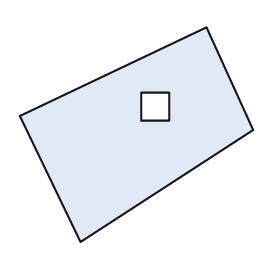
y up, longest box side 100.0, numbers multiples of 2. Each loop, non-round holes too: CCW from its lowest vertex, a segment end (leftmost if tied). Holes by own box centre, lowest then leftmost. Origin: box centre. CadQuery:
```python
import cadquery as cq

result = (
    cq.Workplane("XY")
    .moveTo(-24.0, -46.0)
    .lineTo(50.0, 2.0)
    .lineTo(30.0, 46.0)
    .lineTo(-50.0, 8.0)
    .close()
    .moveTo(2.0, 6.0)
    .lineTo(14.0, 6.0)
    .lineTo(14.0, 18.0)
    .lineTo(2.0, 18.0)
    .close()
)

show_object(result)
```